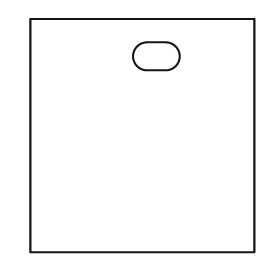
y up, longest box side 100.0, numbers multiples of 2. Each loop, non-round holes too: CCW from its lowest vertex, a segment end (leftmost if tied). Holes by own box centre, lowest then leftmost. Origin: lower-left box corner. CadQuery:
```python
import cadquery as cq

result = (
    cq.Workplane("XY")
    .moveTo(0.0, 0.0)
    .lineTo(96.0, 0.0)
    .lineTo(96.0, 100.0)
    .lineTo(0.0, 100.0)
    .close()
    .moveTo(50.0, 78.0)
    .lineTo(58.0, 78.0)
    .threePointArc((64.0, 84.0), (58.0, 90.0))
    .lineTo(50.0, 90.0)
    .threePointArc((44.0, 84.0), (50.0, 78.0))
    .close()
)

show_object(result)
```